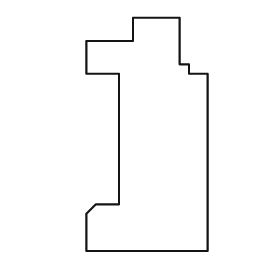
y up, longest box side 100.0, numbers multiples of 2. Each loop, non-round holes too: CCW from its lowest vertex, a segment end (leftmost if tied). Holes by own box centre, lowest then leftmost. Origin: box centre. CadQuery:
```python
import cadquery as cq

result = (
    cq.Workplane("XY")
    .moveTo(-26.0, -50.0)
    .lineTo(26.0, -50.0)
    .lineTo(26.0, 26.0)
    .lineTo(18.0, 26.0)
    .lineTo(18.0, 30.0)
    .lineTo(14.0, 30.0)
    .lineTo(14.0, 50.0)
    .lineTo(-6.0, 50.0)
    .lineTo(-6.0, 40.0)
    .lineTo(-26.0, 40.0)
    .lineTo(-26.0, 26.0)
    .lineTo(-12.0, 26.0)
    .lineTo(-12.0, -30.0)
    .lineTo(-22.0, -30.0)
    .lineTo(-26.0, -34.0)
    .close()
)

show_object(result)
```